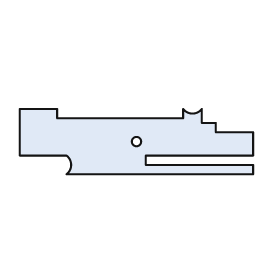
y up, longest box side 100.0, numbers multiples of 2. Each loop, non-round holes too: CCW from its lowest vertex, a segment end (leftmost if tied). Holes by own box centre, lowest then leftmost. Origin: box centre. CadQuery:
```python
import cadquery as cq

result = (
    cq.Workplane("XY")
    .moveTo(-30.0, -14.0)
    .lineTo(50.0, -14.0)
    .lineTo(50.0, -10.0)
    .lineTo(4.0, -10.0)
    .lineTo(4.0, -6.0)
    .lineTo(50.0, -6.0)
    .lineTo(50.0, 4.0)
    .lineTo(34.0, 4.0)
    .lineTo(34.0, 8.0)
    .lineTo(28.0, 8.0)
    .lineTo(28.0, 14.0)
    .threePointArc((24.0, 12.0), (20.0, 14.0))
    .lineTo(20.0, 10.0)
    .lineTo(-34.0, 10.0)
    .lineTo(-34.0, 14.0)
    .lineTo(-50.0, 14.0)
    .lineTo(-50.0, -6.0)
    .lineTo(-30.0, -6.0)
    .threePointArc((-28.0, -10.0), (-30.0, -14.0))
    .close()
    .moveTo(0.0, 0.0)
    .circle(2.0)
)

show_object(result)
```